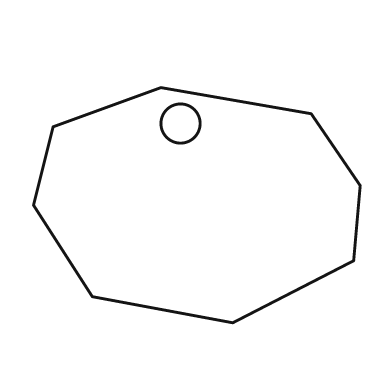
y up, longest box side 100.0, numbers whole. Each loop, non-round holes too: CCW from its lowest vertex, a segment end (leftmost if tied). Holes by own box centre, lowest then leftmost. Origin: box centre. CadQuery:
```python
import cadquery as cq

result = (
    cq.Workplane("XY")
    .moveTo(11.0, -36.0)
    .lineTo(48.0, -17.0)
    .lineTo(50.0, 6.0)
    .lineTo(35.0, 28.0)
    .lineTo(-11.0, 36.0)
    .lineTo(-44.0, 24.0)
    .lineTo(-50.0, 0.0)
    .lineTo(-32.0, -28.0)
    .close()
    .moveTo(-5.0, 25.0)
    .circle(6.0)
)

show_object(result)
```